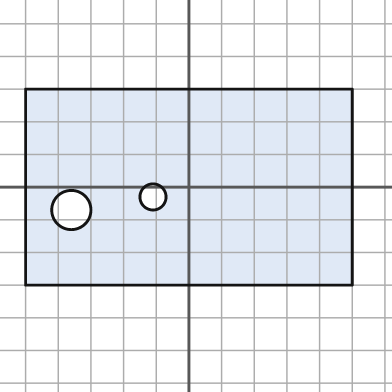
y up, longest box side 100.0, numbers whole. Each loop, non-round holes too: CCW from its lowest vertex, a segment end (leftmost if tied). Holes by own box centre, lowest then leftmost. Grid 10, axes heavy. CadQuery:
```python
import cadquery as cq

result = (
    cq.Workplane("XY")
    .moveTo(-50.0, -30.0)
    .lineTo(50.0, -30.0)
    .lineTo(50.0, 30.0)
    .lineTo(-50.0, 30.0)
    .close()
    .moveTo(-36.0, -7.0)
    .circle(6.0)
    .moveTo(-11.0, -3.0)
    .circle(4.0)
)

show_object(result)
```